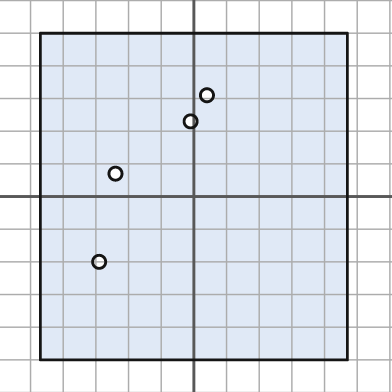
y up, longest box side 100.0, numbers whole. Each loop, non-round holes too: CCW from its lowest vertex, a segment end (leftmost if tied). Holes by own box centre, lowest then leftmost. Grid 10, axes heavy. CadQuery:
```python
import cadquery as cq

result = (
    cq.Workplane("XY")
    .moveTo(-47.0, -50.0)
    .lineTo(47.0, -50.0)
    .lineTo(47.0, 50.0)
    .lineTo(-47.0, 50.0)
    .close()
    .moveTo(-29.0, -20.0)
    .circle(2.0)
    .moveTo(-24.0, 7.0)
    .circle(2.0)
    .moveTo(-1.0, 23.0)
    .circle(2.0)
    .moveTo(4.0, 31.0)
    .circle(2.0)
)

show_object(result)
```